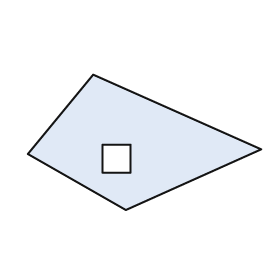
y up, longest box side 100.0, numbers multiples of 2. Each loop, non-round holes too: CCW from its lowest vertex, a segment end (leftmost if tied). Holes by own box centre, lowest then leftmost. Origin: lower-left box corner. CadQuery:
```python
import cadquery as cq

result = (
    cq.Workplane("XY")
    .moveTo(42.0, 0.0)
    .lineTo(100.0, 26.0)
    .lineTo(28.0, 58.0)
    .lineTo(0.0, 24.0)
    .close()
    .moveTo(32.0, 16.0)
    .lineTo(44.0, 16.0)
    .lineTo(44.0, 28.0)
    .lineTo(32.0, 28.0)
    .close()
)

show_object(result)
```